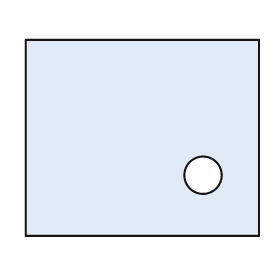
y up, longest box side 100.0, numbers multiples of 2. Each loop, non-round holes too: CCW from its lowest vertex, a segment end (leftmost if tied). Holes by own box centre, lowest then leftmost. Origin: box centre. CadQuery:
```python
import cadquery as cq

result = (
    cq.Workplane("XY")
    .moveTo(-50.0, -42.0)
    .lineTo(50.0, -42.0)
    .lineTo(50.0, 42.0)
    .lineTo(-50.0, 42.0)
    .close()
    .moveTo(26.0, -16.0)
    .circle(8.0)
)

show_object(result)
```